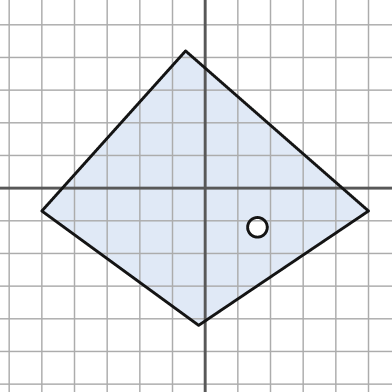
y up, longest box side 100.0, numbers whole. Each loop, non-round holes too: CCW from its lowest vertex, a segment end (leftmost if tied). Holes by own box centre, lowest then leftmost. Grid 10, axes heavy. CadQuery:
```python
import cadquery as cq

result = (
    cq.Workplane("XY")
    .moveTo(-2.0, -42.0)
    .lineTo(50.0, -7.0)
    .lineTo(-6.0, 42.0)
    .lineTo(-50.0, -7.0)
    .close()
    .moveTo(16.0, -12.0)
    .circle(3.0)
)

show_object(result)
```